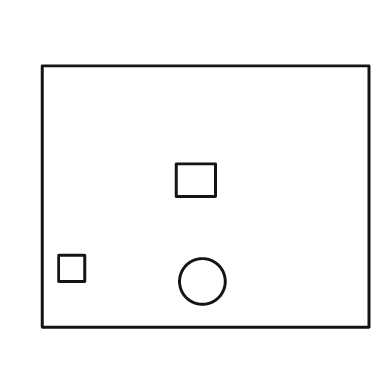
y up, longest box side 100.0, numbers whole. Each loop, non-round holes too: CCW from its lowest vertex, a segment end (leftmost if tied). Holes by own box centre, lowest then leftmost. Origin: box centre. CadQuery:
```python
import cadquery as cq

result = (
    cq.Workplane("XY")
    .moveTo(-50.0, -40.0)
    .lineTo(50.0, -40.0)
    .lineTo(50.0, 40.0)
    .lineTo(-50.0, 40.0)
    .close()
    .moveTo(-1.0, -26.0)
    .circle(7.0)
    .moveTo(-45.0, -26.0)
    .lineTo(-37.0, -26.0)
    .lineTo(-37.0, -18.0)
    .lineTo(-45.0, -18.0)
    .close()
    .moveTo(-9.0, 0.0)
    .lineTo(3.0, 0.0)
    .lineTo(3.0, 10.0)
    .lineTo(-9.0, 10.0)
    .close()
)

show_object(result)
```